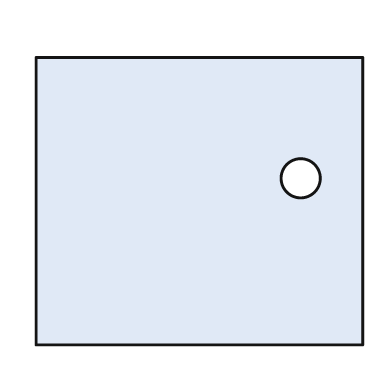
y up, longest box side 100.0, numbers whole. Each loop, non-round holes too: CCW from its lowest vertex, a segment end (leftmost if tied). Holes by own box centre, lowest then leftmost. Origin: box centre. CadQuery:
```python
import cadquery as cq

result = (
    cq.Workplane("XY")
    .moveTo(-50.0, -44.0)
    .lineTo(50.0, -44.0)
    .lineTo(50.0, 44.0)
    .lineTo(-50.0, 44.0)
    .close()
    .moveTo(31.0, 7.0)
    .circle(6.0)
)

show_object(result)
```